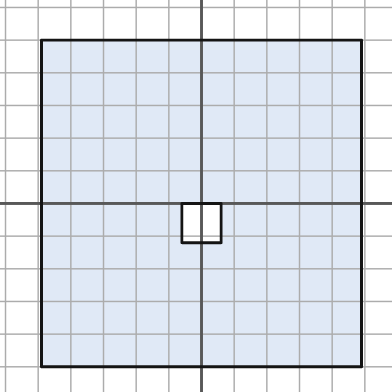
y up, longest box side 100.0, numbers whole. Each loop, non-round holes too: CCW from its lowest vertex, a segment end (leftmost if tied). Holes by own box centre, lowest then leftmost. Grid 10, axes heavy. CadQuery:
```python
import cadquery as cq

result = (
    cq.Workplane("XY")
    .moveTo(-49.0, -50.0)
    .lineTo(49.0, -50.0)
    .lineTo(49.0, 50.0)
    .lineTo(-49.0, 50.0)
    .close()
    .moveTo(-6.0, -12.0)
    .lineTo(6.0, -12.0)
    .lineTo(6.0, 0.0)
    .lineTo(-6.0, 0.0)
    .close()
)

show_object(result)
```